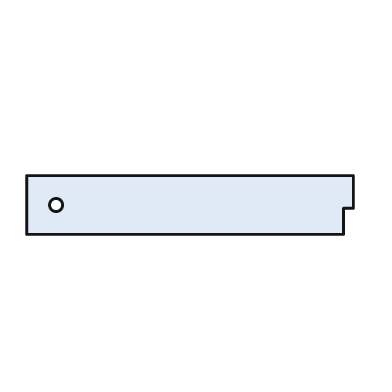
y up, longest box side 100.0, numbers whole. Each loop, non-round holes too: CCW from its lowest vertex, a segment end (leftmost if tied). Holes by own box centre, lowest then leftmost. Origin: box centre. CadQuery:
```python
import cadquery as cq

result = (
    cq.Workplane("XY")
    .moveTo(-50.0, -9.0)
    .lineTo(47.0, -9.0)
    .lineTo(47.0, -1.0)
    .lineTo(50.0, -1.0)
    .lineTo(50.0, 9.0)
    .lineTo(-50.0, 9.0)
    .close()
    .moveTo(-41.0, 0.0)
    .circle(2.0)
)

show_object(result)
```